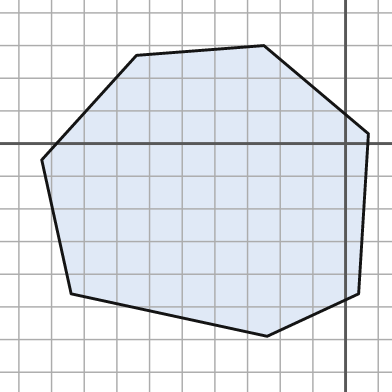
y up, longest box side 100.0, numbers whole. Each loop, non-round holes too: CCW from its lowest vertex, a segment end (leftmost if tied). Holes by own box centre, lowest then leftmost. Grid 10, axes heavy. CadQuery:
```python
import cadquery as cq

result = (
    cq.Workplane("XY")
    .moveTo(-24.0, -59.0)
    .lineTo(4.0, -46.0)
    .lineTo(7.0, 3.0)
    .lineTo(-25.0, 30.0)
    .lineTo(-64.0, 27.0)
    .lineTo(-93.0, -5.0)
    .lineTo(-84.0, -46.0)
    .close()
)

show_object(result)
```